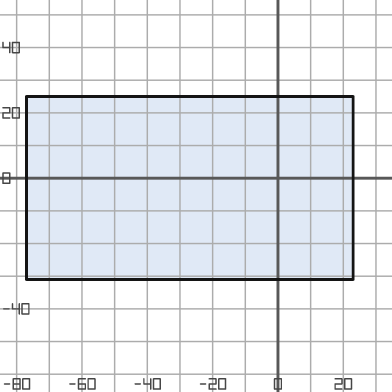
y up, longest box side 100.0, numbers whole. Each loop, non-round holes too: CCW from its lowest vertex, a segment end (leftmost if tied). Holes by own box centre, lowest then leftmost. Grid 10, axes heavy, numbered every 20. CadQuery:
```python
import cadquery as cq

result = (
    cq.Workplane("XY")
    .moveTo(-77.0, -31.0)
    .lineTo(23.0, -31.0)
    .lineTo(23.0, 25.0)
    .lineTo(-77.0, 25.0)
    .close()
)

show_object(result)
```